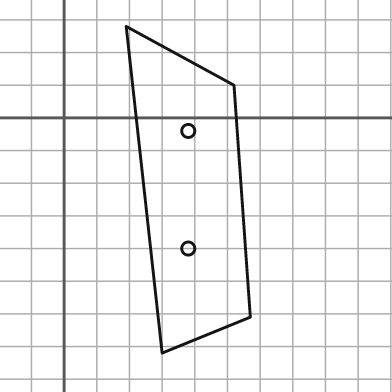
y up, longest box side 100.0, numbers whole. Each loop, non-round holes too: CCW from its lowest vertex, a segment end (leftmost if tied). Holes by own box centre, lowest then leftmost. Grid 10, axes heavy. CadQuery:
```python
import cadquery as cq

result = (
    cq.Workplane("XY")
    .moveTo(30.0, -72.0)
    .lineTo(57.0, -61.0)
    .lineTo(52.0, 10.0)
    .lineTo(19.0, 28.0)
    .close()
    .moveTo(38.0, -40.0)
    .circle(2.0)
    .moveTo(38.0, -4.0)
    .circle(2.0)
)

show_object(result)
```